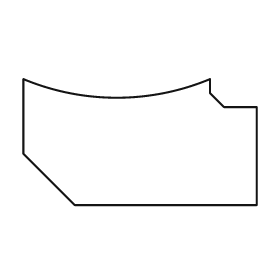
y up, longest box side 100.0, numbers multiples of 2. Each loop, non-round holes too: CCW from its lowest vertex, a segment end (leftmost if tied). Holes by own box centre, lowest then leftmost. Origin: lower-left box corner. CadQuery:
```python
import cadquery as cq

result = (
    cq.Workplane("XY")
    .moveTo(22.0, 0.0)
    .lineTo(100.0, 0.0)
    .lineTo(100.0, 42.0)
    .lineTo(86.0, 42.0)
    .lineTo(80.0, 48.0)
    .lineTo(80.0, 54.0)
    .threePointArc((40.0, 46.0), (0.0, 54.0))
    .lineTo(0.0, 22.0)
    .close()
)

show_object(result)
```